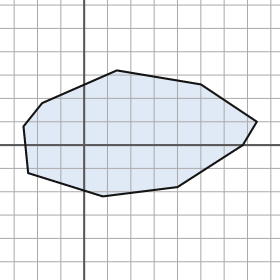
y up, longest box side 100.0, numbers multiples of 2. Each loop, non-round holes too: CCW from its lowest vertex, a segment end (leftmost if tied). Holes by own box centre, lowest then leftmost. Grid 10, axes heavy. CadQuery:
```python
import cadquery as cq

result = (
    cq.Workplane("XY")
    .moveTo(8.0, -22.0)
    .lineTo(40.0, -18.0)
    .lineTo(68.0, 0.0)
    .lineTo(74.0, 10.0)
    .lineTo(50.0, 26.0)
    .lineTo(14.0, 32.0)
    .lineTo(-18.0, 18.0)
    .lineTo(-26.0, 8.0)
    .lineTo(-24.0, -12.0)
    .close()
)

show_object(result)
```